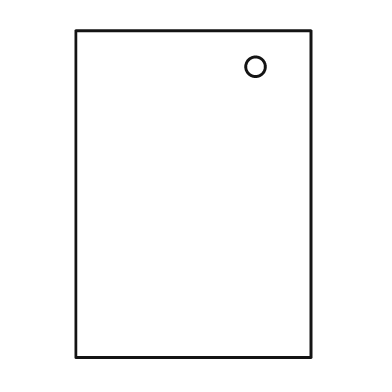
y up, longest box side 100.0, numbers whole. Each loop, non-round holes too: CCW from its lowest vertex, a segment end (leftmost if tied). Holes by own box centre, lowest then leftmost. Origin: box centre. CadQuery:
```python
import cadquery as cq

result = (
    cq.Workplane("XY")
    .moveTo(-36.0, -50.0)
    .lineTo(36.0, -50.0)
    .lineTo(36.0, 50.0)
    .lineTo(-36.0, 50.0)
    .close()
    .moveTo(19.0, 39.0)
    .circle(3.0)
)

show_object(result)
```